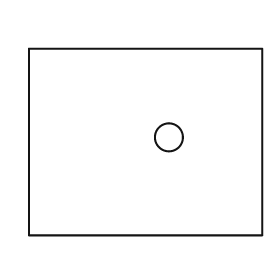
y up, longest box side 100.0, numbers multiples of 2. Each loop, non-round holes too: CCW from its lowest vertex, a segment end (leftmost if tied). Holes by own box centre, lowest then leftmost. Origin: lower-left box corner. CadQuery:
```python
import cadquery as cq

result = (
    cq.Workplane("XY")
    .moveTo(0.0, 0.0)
    .lineTo(100.0, 0.0)
    .lineTo(100.0, 80.0)
    .lineTo(0.0, 80.0)
    .close()
    .moveTo(60.0, 42.0)
    .circle(6.0)
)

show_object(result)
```